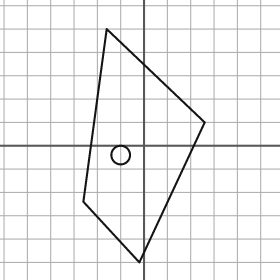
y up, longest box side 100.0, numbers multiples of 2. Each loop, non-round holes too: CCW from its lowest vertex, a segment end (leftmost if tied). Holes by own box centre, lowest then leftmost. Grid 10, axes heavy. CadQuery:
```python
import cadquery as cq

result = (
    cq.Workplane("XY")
    .moveTo(-2.0, -50.0)
    .lineTo(26.0, 10.0)
    .lineTo(-16.0, 50.0)
    .lineTo(-26.0, -24.0)
    .close()
    .moveTo(-10.0, -4.0)
    .circle(4.0)
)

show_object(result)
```